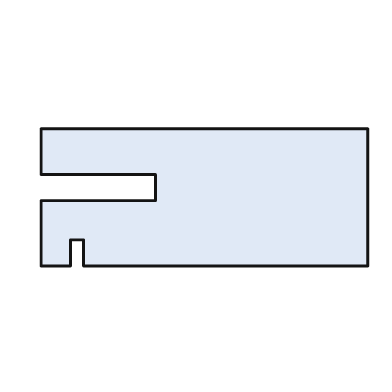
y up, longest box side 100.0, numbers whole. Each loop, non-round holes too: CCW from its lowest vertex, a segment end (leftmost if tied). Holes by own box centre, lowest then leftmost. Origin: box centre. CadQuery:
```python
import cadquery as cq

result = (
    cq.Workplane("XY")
    .moveTo(-50.0, -21.0)
    .lineTo(-41.0, -21.0)
    .lineTo(-41.0, -13.0)
    .lineTo(-37.0, -13.0)
    .lineTo(-37.0, -21.0)
    .lineTo(50.0, -21.0)
    .lineTo(50.0, 21.0)
    .lineTo(-50.0, 21.0)
    .lineTo(-50.0, 7.0)
    .lineTo(-15.0, 7.0)
    .lineTo(-15.0, -1.0)
    .lineTo(-50.0, -1.0)
    .close()
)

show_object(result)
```